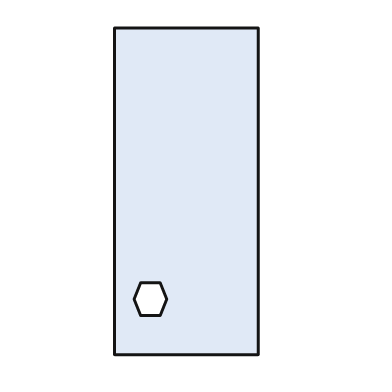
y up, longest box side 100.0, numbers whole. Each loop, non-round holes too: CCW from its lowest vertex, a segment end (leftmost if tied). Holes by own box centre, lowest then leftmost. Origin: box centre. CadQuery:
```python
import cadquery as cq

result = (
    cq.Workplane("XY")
    .moveTo(-22.0, -50.0)
    .lineTo(22.0, -50.0)
    .lineTo(22.0, 50.0)
    .lineTo(-22.0, 50.0)
    .close()
    .moveTo(-14.0, -38.0)
    .lineTo(-8.0, -38.0)
    .lineTo(-6.0, -33.0)
    .lineTo(-8.0, -28.0)
    .lineTo(-14.0, -28.0)
    .lineTo(-16.0, -33.0)
    .close()
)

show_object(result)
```